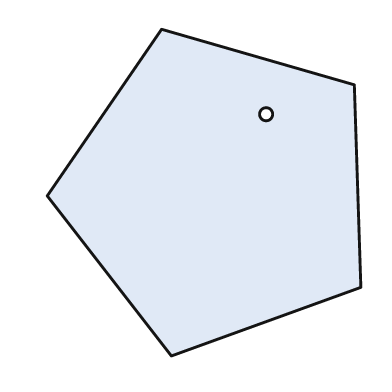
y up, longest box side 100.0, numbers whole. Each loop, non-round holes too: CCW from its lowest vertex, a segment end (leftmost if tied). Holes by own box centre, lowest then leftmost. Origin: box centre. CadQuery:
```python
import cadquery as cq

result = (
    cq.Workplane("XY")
    .moveTo(-10.0, -50.0)
    .lineTo(48.0, -29.0)
    .lineTo(46.0, 33.0)
    .lineTo(-13.0, 50.0)
    .lineTo(-48.0, -1.0)
    .close()
    .moveTo(19.0, 24.0)
    .circle(2.0)
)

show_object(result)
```